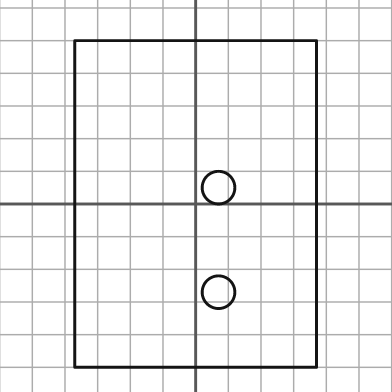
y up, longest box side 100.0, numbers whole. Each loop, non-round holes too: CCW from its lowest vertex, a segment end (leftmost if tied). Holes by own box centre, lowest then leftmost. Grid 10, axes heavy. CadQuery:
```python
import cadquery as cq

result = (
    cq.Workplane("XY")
    .moveTo(-37.0, -50.0)
    .lineTo(37.0, -50.0)
    .lineTo(37.0, 50.0)
    .lineTo(-37.0, 50.0)
    .close()
    .moveTo(7.0, -27.0)
    .circle(5.0)
    .moveTo(7.0, 5.0)
    .circle(5.0)
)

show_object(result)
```